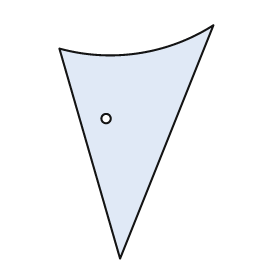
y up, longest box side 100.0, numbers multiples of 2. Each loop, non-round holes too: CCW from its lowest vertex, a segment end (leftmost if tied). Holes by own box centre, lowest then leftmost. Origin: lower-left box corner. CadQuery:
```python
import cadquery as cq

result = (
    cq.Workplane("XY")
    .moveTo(26.0, 0.0)
    .lineTo(66.0, 100.0)
    .threePointArc((34.0, 88.0), (0.0, 90.0))
    .close()
    .moveTo(20.0, 60.0)
    .circle(2.0)
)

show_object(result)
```